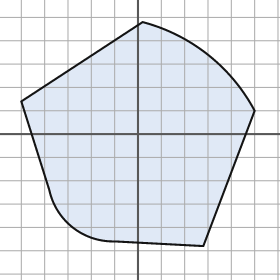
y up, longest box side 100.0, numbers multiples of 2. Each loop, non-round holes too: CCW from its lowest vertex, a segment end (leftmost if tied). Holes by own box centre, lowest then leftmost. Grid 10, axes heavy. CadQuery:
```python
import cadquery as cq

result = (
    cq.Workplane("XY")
    .moveTo(28.0, -48.0)
    .lineTo(50.0, 10.0)
    .threePointArc((30.0, 34.0), (2.0, 48.0))
    .lineTo(-50.0, 14.0)
    .lineTo(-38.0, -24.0)
    .threePointArc((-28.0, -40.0), (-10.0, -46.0))
    .close()
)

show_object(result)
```